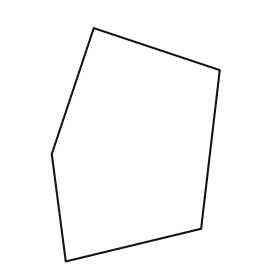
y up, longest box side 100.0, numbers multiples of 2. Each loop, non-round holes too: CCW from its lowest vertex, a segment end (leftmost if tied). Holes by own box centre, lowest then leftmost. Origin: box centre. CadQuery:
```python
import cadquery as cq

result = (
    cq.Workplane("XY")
    .moveTo(-30.0, -50.0)
    .lineTo(28.0, -36.0)
    .lineTo(36.0, 32.0)
    .lineTo(-18.0, 50.0)
    .lineTo(-36.0, -4.0)
    .close()
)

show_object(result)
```